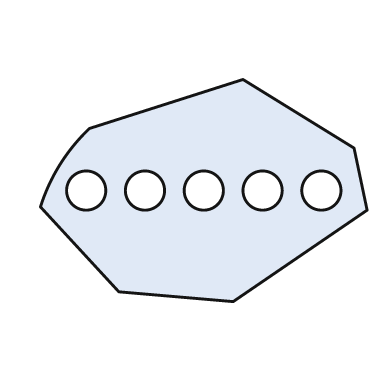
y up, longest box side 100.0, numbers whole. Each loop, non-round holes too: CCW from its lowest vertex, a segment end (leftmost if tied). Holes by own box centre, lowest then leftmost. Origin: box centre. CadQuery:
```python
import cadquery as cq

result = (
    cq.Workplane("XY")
    .moveTo(9.0, -34.0)
    .lineTo(50.0, -6.0)
    .lineTo(46.0, 13.0)
    .lineTo(12.0, 34.0)
    .lineTo(-35.0, 19.0)
    .threePointArc((-44.0, 8.0), (-50.0, -5.0))
    .lineTo(-26.0, -31.0)
    .close()
    .moveTo(-36.0, 0.0)
    .circle(6.0)
    .moveTo(-18.0, 0.0)
    .circle(6.0)
    .moveTo(0.0, 0.0)
    .circle(6.0)
    .moveTo(18.0, 0.0)
    .circle(6.0)
    .moveTo(36.0, 0.0)
    .circle(6.0)
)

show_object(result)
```